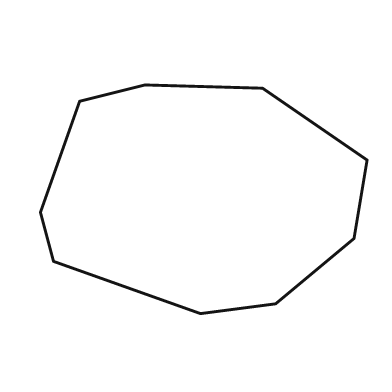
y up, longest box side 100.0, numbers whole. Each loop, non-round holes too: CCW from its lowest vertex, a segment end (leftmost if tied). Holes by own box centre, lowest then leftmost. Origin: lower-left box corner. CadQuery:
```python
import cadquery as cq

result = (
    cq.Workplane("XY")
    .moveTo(49.0, 0.0)
    .lineTo(72.0, 3.0)
    .lineTo(96.0, 23.0)
    .lineTo(100.0, 47.0)
    .lineTo(68.0, 69.0)
    .lineTo(32.0, 70.0)
    .lineTo(12.0, 65.0)
    .lineTo(0.0, 31.0)
    .lineTo(4.0, 16.0)
    .close()
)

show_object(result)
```